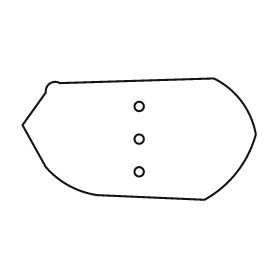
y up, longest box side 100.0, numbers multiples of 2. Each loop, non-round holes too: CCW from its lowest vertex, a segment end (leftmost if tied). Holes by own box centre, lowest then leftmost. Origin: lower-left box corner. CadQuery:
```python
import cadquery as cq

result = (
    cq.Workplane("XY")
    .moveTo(78.0, 0.0)
    .threePointArc((92.0, 12.0), (100.0, 28.0))
    .threePointArc((94.0, 42.0), (82.0, 52.0))
    .lineTo(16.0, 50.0)
    .threePointArc((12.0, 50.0), (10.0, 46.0))
    .lineTo(0.0, 32.0)
    .lineTo(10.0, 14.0)
    .threePointArc((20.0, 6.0), (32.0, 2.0))
    .close()
    .moveTo(50.0, 12.0)
    .circle(2.0)
    .moveTo(50.0, 26.0)
    .circle(2.0)
    .moveTo(50.0, 40.0)
    .circle(2.0)
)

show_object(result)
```